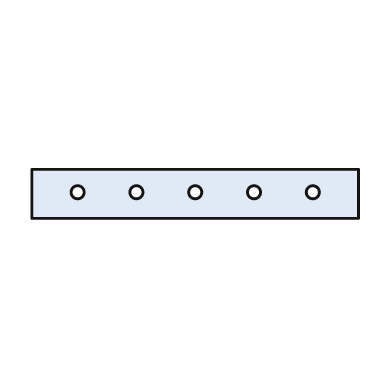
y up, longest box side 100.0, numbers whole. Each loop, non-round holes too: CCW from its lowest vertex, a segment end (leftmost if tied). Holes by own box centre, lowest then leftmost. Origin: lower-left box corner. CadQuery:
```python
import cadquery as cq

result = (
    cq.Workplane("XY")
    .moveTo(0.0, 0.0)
    .lineTo(100.0, 0.0)
    .lineTo(100.0, 15.0)
    .lineTo(0.0, 15.0)
    .close()
    .moveTo(14.0, 8.0)
    .circle(2.0)
    .moveTo(32.0, 8.0)
    .circle(2.0)
    .moveTo(50.0, 8.0)
    .circle(2.0)
    .moveTo(68.0, 8.0)
    .circle(2.0)
    .moveTo(86.0, 8.0)
    .circle(2.0)
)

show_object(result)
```